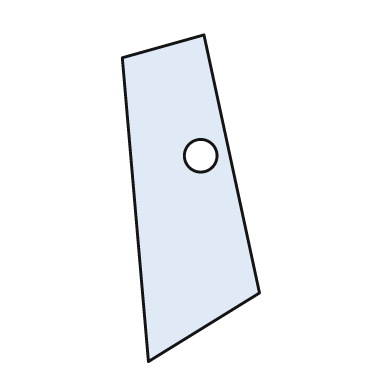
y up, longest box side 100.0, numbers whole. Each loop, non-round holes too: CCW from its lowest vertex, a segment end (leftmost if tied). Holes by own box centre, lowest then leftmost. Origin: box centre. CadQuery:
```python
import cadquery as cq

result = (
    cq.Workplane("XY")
    .moveTo(-13.0, -50.0)
    .lineTo(21.0, -29.0)
    .lineTo(4.0, 50.0)
    .lineTo(-21.0, 43.0)
    .close()
    .moveTo(3.0, 13.0)
    .circle(5.0)
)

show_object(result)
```